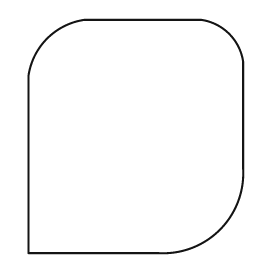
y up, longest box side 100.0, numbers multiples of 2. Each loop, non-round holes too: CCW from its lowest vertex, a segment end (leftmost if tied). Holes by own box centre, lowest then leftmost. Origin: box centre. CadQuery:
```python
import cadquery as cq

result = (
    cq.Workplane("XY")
    .moveTo(-46.0, -50.0)
    .lineTo(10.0, -50.0)
    .threePointArc((36.0, -40.0), (46.0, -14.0))
    .lineTo(46.0, 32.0)
    .threePointArc((40.0, 44.0), (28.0, 50.0))
    .lineTo(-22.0, 50.0)
    .threePointArc((-38.0, 42.0), (-46.0, 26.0))
    .close()
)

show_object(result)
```